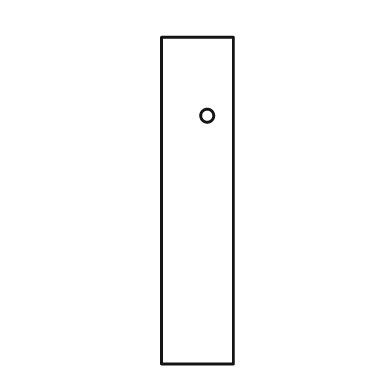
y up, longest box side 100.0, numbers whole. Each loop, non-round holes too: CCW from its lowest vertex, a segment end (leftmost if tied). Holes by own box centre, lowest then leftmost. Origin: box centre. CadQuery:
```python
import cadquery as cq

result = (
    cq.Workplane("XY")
    .moveTo(-11.0, -50.0)
    .lineTo(11.0, -50.0)
    .lineTo(11.0, 50.0)
    .lineTo(-11.0, 50.0)
    .close()
    .moveTo(3.0, 26.0)
    .circle(2.0)
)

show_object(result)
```